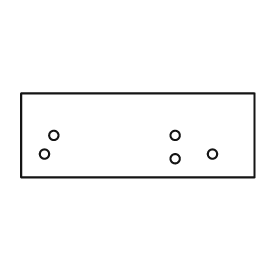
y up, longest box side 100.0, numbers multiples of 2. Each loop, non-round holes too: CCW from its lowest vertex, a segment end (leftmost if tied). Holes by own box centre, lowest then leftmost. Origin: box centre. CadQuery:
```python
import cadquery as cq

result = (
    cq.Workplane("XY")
    .moveTo(-50.0, -18.0)
    .lineTo(50.0, -18.0)
    .lineTo(50.0, 18.0)
    .lineTo(-50.0, 18.0)
    .close()
    .moveTo(16.0, -10.0)
    .circle(2.0)
    .moveTo(-40.0, -8.0)
    .circle(2.0)
    .moveTo(32.0, -8.0)
    .circle(2.0)
    .moveTo(-36.0, 0.0)
    .circle(2.0)
    .moveTo(16.0, 0.0)
    .circle(2.0)
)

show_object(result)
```